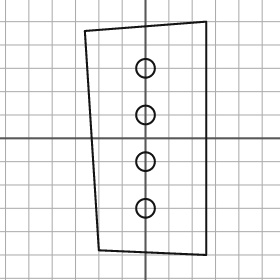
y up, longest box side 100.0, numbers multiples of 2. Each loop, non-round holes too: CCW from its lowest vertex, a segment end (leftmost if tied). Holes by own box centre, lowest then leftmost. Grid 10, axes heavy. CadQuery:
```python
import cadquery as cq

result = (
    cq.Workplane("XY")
    .moveTo(26.0, -50.0)
    .lineTo(26.0, 50.0)
    .lineTo(-26.0, 46.0)
    .lineTo(-20.0, -48.0)
    .close()
    .moveTo(0.0, -30.0)
    .circle(4.0)
    .moveTo(0.0, -10.0)
    .circle(4.0)
    .moveTo(0.0, 10.0)
    .circle(4.0)
    .moveTo(0.0, 30.0)
    .circle(4.0)
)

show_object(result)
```